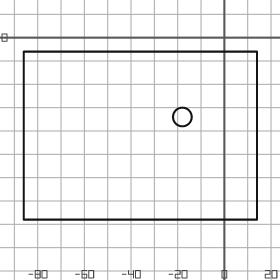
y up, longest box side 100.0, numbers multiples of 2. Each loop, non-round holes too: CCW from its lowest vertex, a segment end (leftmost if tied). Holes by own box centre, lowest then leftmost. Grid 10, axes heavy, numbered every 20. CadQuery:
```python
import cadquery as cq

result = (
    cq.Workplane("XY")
    .moveTo(-86.0, -78.0)
    .lineTo(14.0, -78.0)
    .lineTo(14.0, -6.0)
    .lineTo(-86.0, -6.0)
    .close()
    .moveTo(-18.0, -34.0)
    .circle(4.0)
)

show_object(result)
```